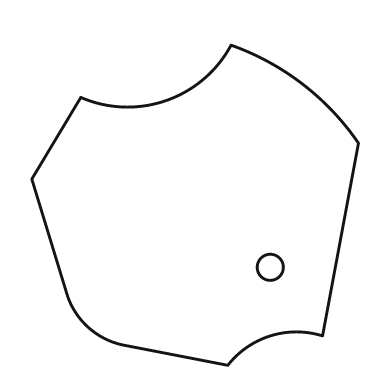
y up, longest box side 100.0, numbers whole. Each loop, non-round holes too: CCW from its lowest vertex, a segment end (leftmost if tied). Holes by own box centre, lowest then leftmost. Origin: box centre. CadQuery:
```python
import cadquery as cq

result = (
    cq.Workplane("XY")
    .moveTo(10.0, -49.0)
    .threePointArc((23.0, -40.0), (39.0, -40.0))
    .lineTo(50.0, 19.0)
    .threePointArc((33.0, 37.0), (11.0, 49.0))
    .threePointArc((-9.0, 32.0), (-35.0, 33.0))
    .lineTo(-50.0, 8.0)
    .lineTo(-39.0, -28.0)
    .threePointArc((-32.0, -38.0), (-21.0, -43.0))
    .close()
    .moveTo(23.0, -19.0)
    .circle(4.0)
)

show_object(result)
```